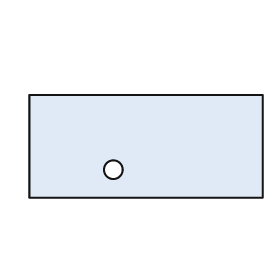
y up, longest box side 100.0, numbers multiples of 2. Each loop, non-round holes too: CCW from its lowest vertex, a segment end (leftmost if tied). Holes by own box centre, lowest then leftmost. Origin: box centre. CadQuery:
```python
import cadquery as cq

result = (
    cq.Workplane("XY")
    .moveTo(-50.0, -22.0)
    .lineTo(50.0, -22.0)
    .lineTo(50.0, 22.0)
    .lineTo(-50.0, 22.0)
    .close()
    .moveTo(-14.0, -10.0)
    .circle(4.0)
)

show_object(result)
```